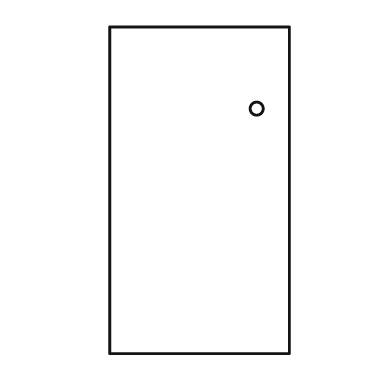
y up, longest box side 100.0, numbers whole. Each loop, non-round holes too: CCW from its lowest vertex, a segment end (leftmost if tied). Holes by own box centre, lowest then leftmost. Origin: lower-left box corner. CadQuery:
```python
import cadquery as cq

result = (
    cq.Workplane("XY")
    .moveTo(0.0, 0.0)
    .lineTo(55.0, 0.0)
    .lineTo(55.0, 100.0)
    .lineTo(0.0, 100.0)
    .close()
    .moveTo(45.0, 75.0)
    .circle(2.0)
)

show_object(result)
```